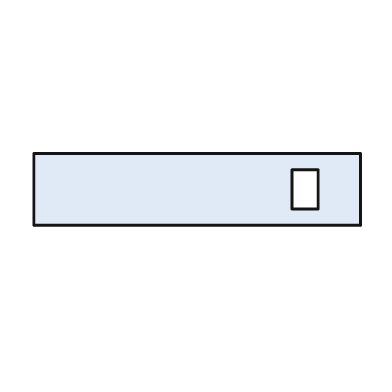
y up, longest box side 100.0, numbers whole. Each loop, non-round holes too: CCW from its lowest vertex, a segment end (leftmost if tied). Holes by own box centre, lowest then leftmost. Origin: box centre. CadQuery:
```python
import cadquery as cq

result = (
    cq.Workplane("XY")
    .moveTo(-50.0, -11.0)
    .lineTo(50.0, -11.0)
    .lineTo(50.0, 11.0)
    .lineTo(-50.0, 11.0)
    .close()
    .moveTo(29.0, -6.0)
    .lineTo(37.0, -6.0)
    .lineTo(37.0, 6.0)
    .lineTo(29.0, 6.0)
    .close()
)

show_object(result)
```